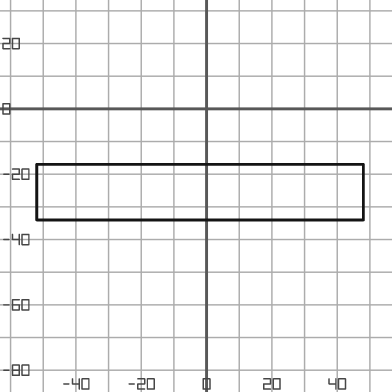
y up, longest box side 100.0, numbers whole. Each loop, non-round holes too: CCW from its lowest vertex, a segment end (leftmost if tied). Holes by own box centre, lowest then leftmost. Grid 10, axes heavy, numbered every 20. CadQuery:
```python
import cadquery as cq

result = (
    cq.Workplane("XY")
    .moveTo(-52.0, -34.0)
    .lineTo(48.0, -34.0)
    .lineTo(48.0, -17.0)
    .lineTo(-52.0, -17.0)
    .close()
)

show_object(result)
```